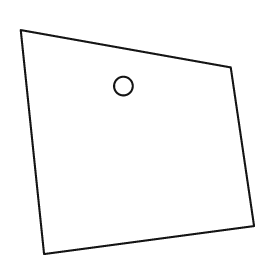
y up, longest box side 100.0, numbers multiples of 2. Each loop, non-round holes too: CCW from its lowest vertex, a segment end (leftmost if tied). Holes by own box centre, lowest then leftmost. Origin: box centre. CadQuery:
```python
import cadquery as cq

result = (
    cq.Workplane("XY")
    .moveTo(-40.0, -48.0)
    .lineTo(50.0, -36.0)
    .lineTo(40.0, 32.0)
    .lineTo(-50.0, 48.0)
    .close()
    .moveTo(-6.0, 24.0)
    .circle(4.0)
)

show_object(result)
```